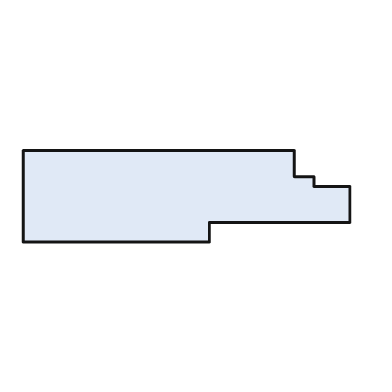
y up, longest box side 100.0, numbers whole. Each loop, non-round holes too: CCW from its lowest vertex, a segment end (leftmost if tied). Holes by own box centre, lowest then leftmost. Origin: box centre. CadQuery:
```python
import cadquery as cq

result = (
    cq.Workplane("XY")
    .moveTo(-50.0, -14.0)
    .lineTo(7.0, -14.0)
    .lineTo(7.0, -8.0)
    .lineTo(50.0, -8.0)
    .lineTo(50.0, 3.0)
    .lineTo(39.0, 3.0)
    .lineTo(39.0, 6.0)
    .lineTo(33.0, 6.0)
    .lineTo(33.0, 14.0)
    .lineTo(-50.0, 14.0)
    .close()
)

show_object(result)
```